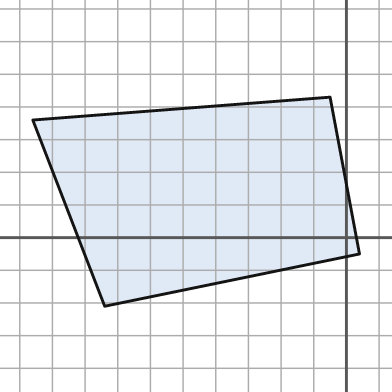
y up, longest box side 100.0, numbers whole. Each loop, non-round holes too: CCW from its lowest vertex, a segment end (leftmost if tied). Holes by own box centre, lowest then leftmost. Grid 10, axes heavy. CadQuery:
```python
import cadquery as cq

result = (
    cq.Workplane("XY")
    .moveTo(-74.0, -21.0)
    .lineTo(4.0, -5.0)
    .lineTo(-5.0, 43.0)
    .lineTo(-96.0, 36.0)
    .close()
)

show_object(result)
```